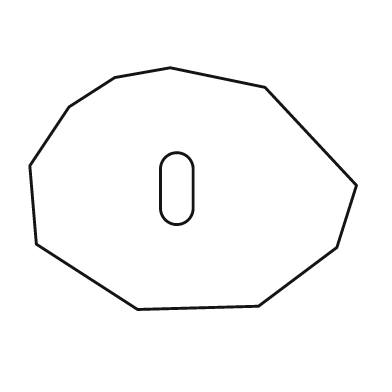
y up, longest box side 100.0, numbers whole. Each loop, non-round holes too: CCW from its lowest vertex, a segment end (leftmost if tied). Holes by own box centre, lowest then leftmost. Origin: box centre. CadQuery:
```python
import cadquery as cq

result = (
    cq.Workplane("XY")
    .moveTo(-17.0, -37.0)
    .lineTo(20.0, -36.0)
    .lineTo(44.0, -18.0)
    .lineTo(50.0, 1.0)
    .lineTo(22.0, 31.0)
    .lineTo(-7.0, 37.0)
    .lineTo(-24.0, 34.0)
    .lineTo(-38.0, 25.0)
    .lineTo(-50.0, 7.0)
    .lineTo(-48.0, -17.0)
    .close()
    .moveTo(-10.0, -6.0)
    .threePointArc((-5.0, -11.0), (0.0, -6.0))
    .lineTo(0.0, 6.0)
    .threePointArc((-5.0, 11.0), (-10.0, 6.0))
    .close()
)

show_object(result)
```